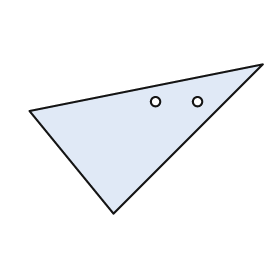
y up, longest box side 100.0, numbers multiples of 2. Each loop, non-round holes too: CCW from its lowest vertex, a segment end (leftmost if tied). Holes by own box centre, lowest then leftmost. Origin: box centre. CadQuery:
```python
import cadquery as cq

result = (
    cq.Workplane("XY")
    .moveTo(-14.0, -32.0)
    .lineTo(50.0, 32.0)
    .lineTo(-50.0, 12.0)
    .close()
    .moveTo(4.0, 16.0)
    .circle(2.0)
    .moveTo(22.0, 16.0)
    .circle(2.0)
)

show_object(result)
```